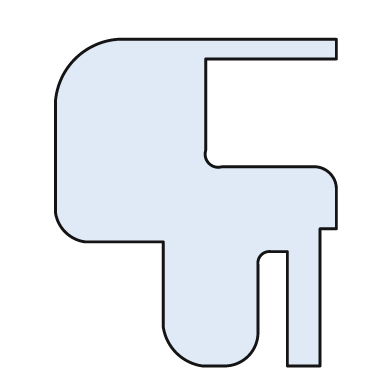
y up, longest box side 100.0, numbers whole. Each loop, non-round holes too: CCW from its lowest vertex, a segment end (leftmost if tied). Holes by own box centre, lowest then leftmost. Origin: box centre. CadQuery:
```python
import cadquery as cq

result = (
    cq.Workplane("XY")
    .moveTo(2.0, -50.0)
    .lineTo(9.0, -50.0)
    .threePointArc((16.0, -47.0), (19.0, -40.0))
    .lineTo(19.0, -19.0)
    .threePointArc((20.0, -16.0), (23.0, -15.0))
    .lineTo(28.0, -15.0)
    .lineTo(28.0, -50.0)
    .lineTo(38.0, -50.0)
    .lineTo(38.0, -8.0)
    .lineTo(43.0, -8.0)
    .lineTo(43.0, 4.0)
    .threePointArc((41.0, 9.0), (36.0, 11.0))
    .lineTo(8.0, 11.0)
    .threePointArc((4.0, 12.0), (3.0, 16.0))
    .lineTo(3.0, 44.0)
    .lineTo(43.0, 44.0)
    .lineTo(43.0, 50.0)
    .lineTo(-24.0, 50.0)
    .threePointArc((-37.0, 44.0), (-43.0, 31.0))
    .lineTo(-43.0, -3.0)
    .threePointArc((-40.0, -9.0), (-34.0, -12.0))
    .lineTo(-10.0, -12.0)
    .lineTo(-10.0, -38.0)
    .threePointArc((-6.0, -46.0), (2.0, -50.0))
    .close()
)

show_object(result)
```